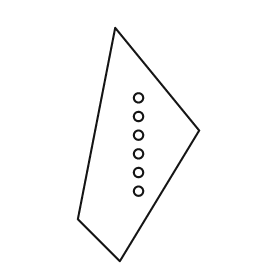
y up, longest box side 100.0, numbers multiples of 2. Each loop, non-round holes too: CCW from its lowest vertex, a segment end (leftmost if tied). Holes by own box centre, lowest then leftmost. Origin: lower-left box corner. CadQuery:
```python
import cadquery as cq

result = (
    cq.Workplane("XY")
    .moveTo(18.0, 0.0)
    .lineTo(52.0, 56.0)
    .lineTo(16.0, 100.0)
    .lineTo(0.0, 18.0)
    .close()
    .moveTo(26.0, 30.0)
    .circle(2.0)
    .moveTo(26.0, 38.0)
    .circle(2.0)
    .moveTo(26.0, 46.0)
    .circle(2.0)
    .moveTo(26.0, 54.0)
    .circle(2.0)
    .moveTo(26.0, 62.0)
    .circle(2.0)
    .moveTo(26.0, 70.0)
    .circle(2.0)
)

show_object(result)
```